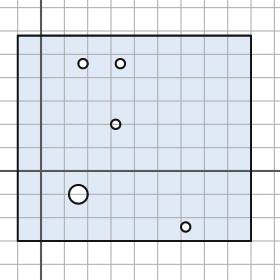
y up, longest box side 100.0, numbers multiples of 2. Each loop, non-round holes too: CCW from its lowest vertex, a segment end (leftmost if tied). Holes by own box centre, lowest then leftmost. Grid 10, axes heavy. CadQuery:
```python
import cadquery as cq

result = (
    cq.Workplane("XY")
    .moveTo(-10.0, -30.0)
    .lineTo(90.0, -30.0)
    .lineTo(90.0, 58.0)
    .lineTo(-10.0, 58.0)
    .close()
    .moveTo(62.0, -24.0)
    .circle(2.0)
    .moveTo(16.0, -10.0)
    .circle(4.0)
    .moveTo(32.0, 20.0)
    .circle(2.0)
    .moveTo(18.0, 46.0)
    .circle(2.0)
    .moveTo(34.0, 46.0)
    .circle(2.0)
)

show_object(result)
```